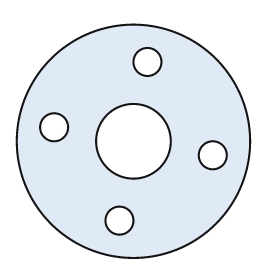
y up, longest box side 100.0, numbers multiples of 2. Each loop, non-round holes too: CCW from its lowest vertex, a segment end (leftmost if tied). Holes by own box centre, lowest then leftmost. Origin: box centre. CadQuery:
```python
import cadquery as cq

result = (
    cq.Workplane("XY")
    .moveTo(0.0, 0.0)
    .circle(50.0)
    .moveTo(-6.0, -34.0)
    .circle(6.0)
    .moveTo(34.0, -6.0)
    .circle(6.0)
    .moveTo(0.0, 0.0)
    .circle(16.0)
    .moveTo(-34.0, 6.0)
    .circle(6.0)
    .moveTo(6.0, 34.0)
    .circle(6.0)
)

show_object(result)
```